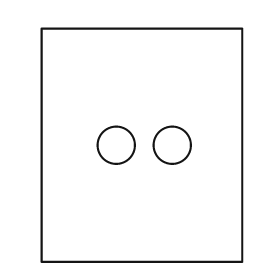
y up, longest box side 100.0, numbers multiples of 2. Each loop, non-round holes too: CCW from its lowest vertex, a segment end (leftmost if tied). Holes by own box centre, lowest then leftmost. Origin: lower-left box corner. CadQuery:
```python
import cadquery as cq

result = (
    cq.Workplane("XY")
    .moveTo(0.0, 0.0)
    .lineTo(86.0, 0.0)
    .lineTo(86.0, 100.0)
    .lineTo(0.0, 100.0)
    .close()
    .moveTo(32.0, 50.0)
    .circle(8.0)
    .moveTo(56.0, 50.0)
    .circle(8.0)
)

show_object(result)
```